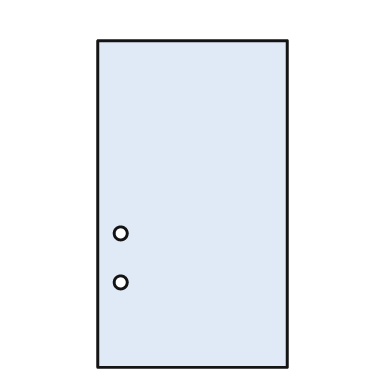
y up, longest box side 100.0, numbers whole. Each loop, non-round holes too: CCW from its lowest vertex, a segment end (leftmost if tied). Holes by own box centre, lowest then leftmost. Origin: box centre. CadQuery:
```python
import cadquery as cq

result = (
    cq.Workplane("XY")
    .moveTo(-29.0, -50.0)
    .lineTo(29.0, -50.0)
    .lineTo(29.0, 50.0)
    .lineTo(-29.0, 50.0)
    .close()
    .moveTo(-22.0, -24.0)
    .circle(2.0)
    .moveTo(-22.0, -9.0)
    .circle(2.0)
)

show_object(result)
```